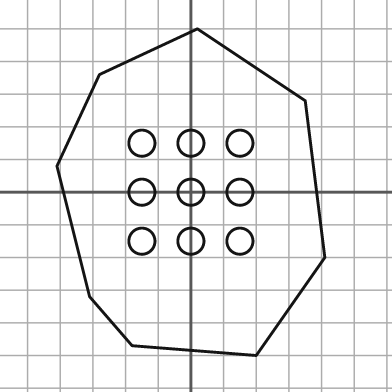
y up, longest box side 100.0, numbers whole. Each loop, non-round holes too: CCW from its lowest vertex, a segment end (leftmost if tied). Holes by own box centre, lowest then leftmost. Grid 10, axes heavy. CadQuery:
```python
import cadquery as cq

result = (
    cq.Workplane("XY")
    .moveTo(20.0, -50.0)
    .lineTo(41.0, -20.0)
    .lineTo(35.0, 28.0)
    .lineTo(2.0, 50.0)
    .lineTo(-28.0, 36.0)
    .lineTo(-41.0, 8.0)
    .lineTo(-31.0, -32.0)
    .lineTo(-18.0, -47.0)
    .close()
    .moveTo(-15.0, -15.0)
    .circle(4.0)
    .moveTo(0.0, -15.0)
    .circle(4.0)
    .moveTo(15.0, -15.0)
    .circle(4.0)
    .moveTo(-15.0, 0.0)
    .circle(4.0)
    .moveTo(0.0, 0.0)
    .circle(4.0)
    .moveTo(15.0, 0.0)
    .circle(4.0)
    .moveTo(-15.0, 15.0)
    .circle(4.0)
    .moveTo(0.0, 15.0)
    .circle(4.0)
    .moveTo(15.0, 15.0)
    .circle(4.0)
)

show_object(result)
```